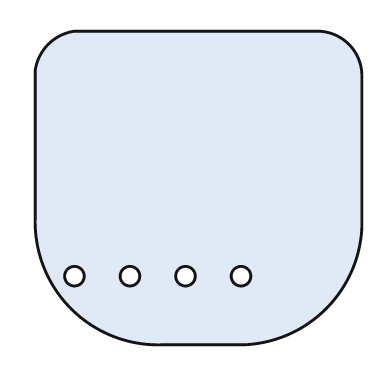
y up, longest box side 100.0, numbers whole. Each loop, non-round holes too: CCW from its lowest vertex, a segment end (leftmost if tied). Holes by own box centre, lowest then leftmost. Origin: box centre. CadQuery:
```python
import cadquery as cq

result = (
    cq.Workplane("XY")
    .moveTo(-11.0, -48.0)
    .lineTo(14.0, -48.0)
    .threePointArc((39.0, -37.0), (50.0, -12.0))
    .lineTo(50.0, 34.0)
    .threePointArc((46.0, 44.0), (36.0, 48.0))
    .lineTo(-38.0, 48.0)
    .threePointArc((-46.0, 44.0), (-50.0, 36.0))
    .lineTo(-50.0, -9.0)
    .threePointArc((-39.0, -37.0), (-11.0, -48.0))
    .close()
    .moveTo(-38.0, -27.0)
    .circle(3.0)
    .moveTo(-21.0, -27.0)
    .circle(3.0)
    .moveTo(-4.0, -27.0)
    .circle(3.0)
    .moveTo(13.0, -27.0)
    .circle(3.0)
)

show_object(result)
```